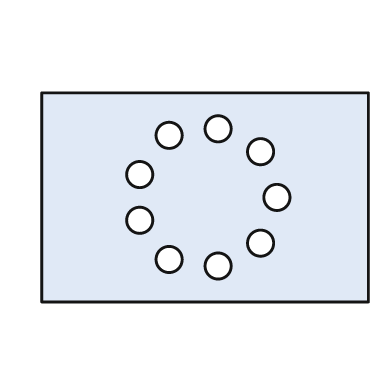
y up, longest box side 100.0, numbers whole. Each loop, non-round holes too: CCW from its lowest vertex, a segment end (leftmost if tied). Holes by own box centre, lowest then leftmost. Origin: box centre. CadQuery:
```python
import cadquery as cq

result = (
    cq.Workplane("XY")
    .moveTo(-50.0, -32.0)
    .lineTo(50.0, -32.0)
    .lineTo(50.0, 32.0)
    .lineTo(-50.0, 32.0)
    .close()
    .moveTo(4.0, -21.0)
    .circle(4.0)
    .moveTo(-11.0, -19.0)
    .circle(4.0)
    .moveTo(17.0, -14.0)
    .circle(4.0)
    .moveTo(-20.0, -7.0)
    .circle(4.0)
    .moveTo(22.0, 0.0)
    .circle(4.0)
    .moveTo(-20.0, 7.0)
    .circle(4.0)
    .moveTo(17.0, 14.0)
    .circle(4.0)
    .moveTo(-11.0, 19.0)
    .circle(4.0)
    .moveTo(4.0, 21.0)
    .circle(4.0)
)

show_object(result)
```